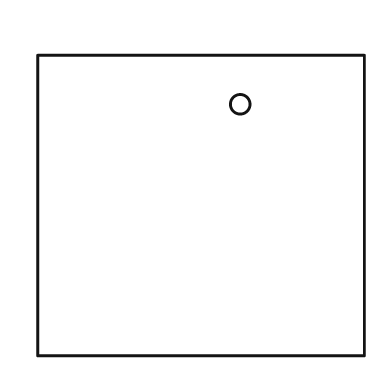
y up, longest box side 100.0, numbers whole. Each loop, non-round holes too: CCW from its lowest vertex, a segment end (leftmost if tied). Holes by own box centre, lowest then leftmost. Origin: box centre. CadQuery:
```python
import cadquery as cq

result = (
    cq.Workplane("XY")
    .moveTo(-50.0, -46.0)
    .lineTo(50.0, -46.0)
    .lineTo(50.0, 46.0)
    .lineTo(-50.0, 46.0)
    .close()
    .moveTo(12.0, 31.0)
    .circle(3.0)
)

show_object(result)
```